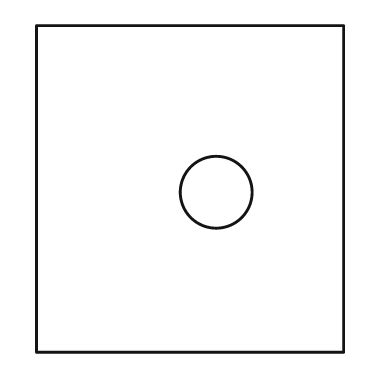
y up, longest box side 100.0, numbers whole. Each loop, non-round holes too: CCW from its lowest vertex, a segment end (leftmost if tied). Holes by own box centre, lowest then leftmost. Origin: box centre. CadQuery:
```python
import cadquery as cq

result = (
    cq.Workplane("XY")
    .moveTo(-47.0, -50.0)
    .lineTo(47.0, -50.0)
    .lineTo(47.0, 50.0)
    .lineTo(-47.0, 50.0)
    .close()
    .moveTo(8.0, -1.0)
    .circle(11.0)
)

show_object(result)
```